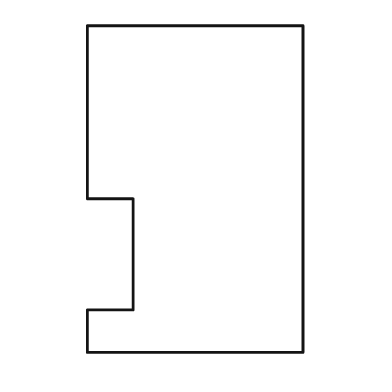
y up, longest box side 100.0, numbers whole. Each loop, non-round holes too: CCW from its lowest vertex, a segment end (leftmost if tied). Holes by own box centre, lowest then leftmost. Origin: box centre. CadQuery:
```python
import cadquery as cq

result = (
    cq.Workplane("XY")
    .moveTo(-33.0, -50.0)
    .lineTo(33.0, -50.0)
    .lineTo(33.0, 50.0)
    .lineTo(-33.0, 50.0)
    .lineTo(-33.0, -3.0)
    .lineTo(-19.0, -3.0)
    .lineTo(-19.0, -37.0)
    .lineTo(-33.0, -37.0)
    .close()
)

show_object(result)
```